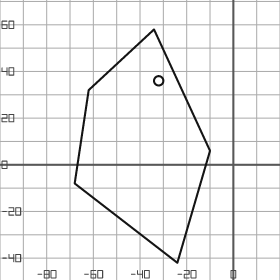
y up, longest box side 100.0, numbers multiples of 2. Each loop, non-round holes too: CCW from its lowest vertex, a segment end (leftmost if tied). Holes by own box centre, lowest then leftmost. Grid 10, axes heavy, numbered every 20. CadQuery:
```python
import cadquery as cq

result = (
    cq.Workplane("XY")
    .moveTo(-24.0, -42.0)
    .lineTo(-10.0, 6.0)
    .lineTo(-34.0, 58.0)
    .lineTo(-62.0, 32.0)
    .lineTo(-68.0, -8.0)
    .close()
    .moveTo(-32.0, 36.0)
    .circle(2.0)
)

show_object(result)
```